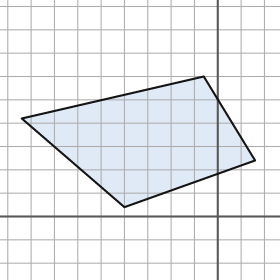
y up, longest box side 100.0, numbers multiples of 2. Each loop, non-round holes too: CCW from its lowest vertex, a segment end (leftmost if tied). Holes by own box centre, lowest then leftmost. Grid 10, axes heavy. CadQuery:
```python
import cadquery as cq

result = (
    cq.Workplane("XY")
    .moveTo(-40.0, 4.0)
    .lineTo(16.0, 24.0)
    .lineTo(-6.0, 60.0)
    .lineTo(-84.0, 42.0)
    .close()
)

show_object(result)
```